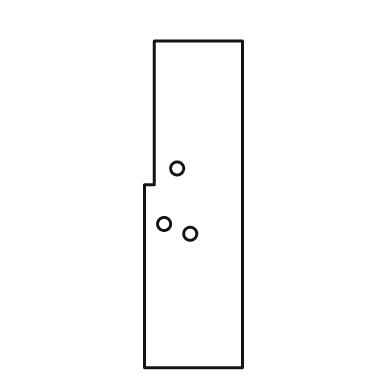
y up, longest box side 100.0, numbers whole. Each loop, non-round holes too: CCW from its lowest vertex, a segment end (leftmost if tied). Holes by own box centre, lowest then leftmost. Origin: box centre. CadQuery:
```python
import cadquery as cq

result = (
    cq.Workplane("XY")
    .moveTo(-15.0, -50.0)
    .lineTo(15.0, -50.0)
    .lineTo(15.0, 50.0)
    .lineTo(-12.0, 50.0)
    .lineTo(-12.0, 6.0)
    .lineTo(-15.0, 6.0)
    .close()
    .moveTo(-1.0, -9.0)
    .circle(2.0)
    .moveTo(-9.0, -6.0)
    .circle(2.0)
    .moveTo(-5.0, 11.0)
    .circle(2.0)
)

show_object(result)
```